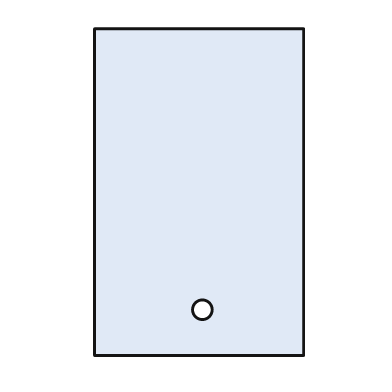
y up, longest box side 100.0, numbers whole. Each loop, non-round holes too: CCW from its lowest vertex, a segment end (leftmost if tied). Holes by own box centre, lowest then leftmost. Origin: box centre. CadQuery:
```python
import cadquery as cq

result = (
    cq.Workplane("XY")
    .moveTo(-32.0, -50.0)
    .lineTo(32.0, -50.0)
    .lineTo(32.0, 50.0)
    .lineTo(-32.0, 50.0)
    .close()
    .moveTo(1.0, -36.0)
    .circle(3.0)
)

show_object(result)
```